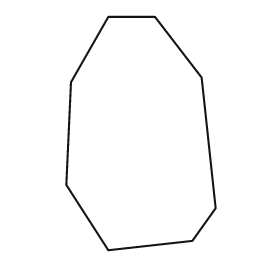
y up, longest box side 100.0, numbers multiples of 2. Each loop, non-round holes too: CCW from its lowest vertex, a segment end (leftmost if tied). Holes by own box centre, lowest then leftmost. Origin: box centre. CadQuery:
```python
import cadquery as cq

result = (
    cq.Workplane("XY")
    .moveTo(-14.0, -50.0)
    .lineTo(22.0, -46.0)
    .lineTo(32.0, -32.0)
    .lineTo(26.0, 24.0)
    .lineTo(6.0, 50.0)
    .lineTo(-14.0, 50.0)
    .lineTo(-30.0, 22.0)
    .lineTo(-32.0, -22.0)
    .close()
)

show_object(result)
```